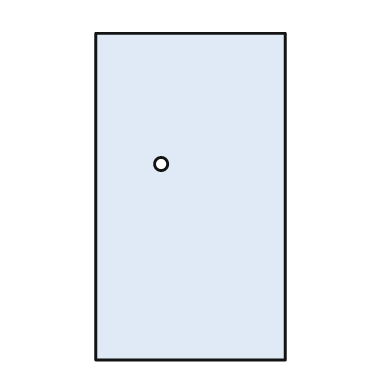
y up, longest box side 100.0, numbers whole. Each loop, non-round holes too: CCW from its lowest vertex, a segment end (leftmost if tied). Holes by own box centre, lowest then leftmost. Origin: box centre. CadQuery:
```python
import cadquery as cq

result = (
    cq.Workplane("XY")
    .moveTo(-29.0, -50.0)
    .lineTo(29.0, -50.0)
    .lineTo(29.0, 50.0)
    .lineTo(-29.0, 50.0)
    .close()
    .moveTo(-9.0, 10.0)
    .circle(2.0)
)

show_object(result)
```